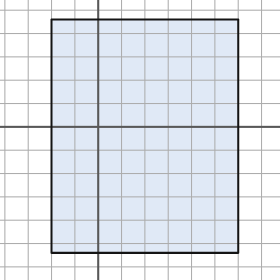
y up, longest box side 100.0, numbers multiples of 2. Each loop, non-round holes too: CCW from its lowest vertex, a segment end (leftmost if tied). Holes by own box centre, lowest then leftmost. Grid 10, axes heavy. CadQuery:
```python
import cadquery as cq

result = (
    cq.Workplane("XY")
    .moveTo(-20.0, -54.0)
    .lineTo(60.0, -54.0)
    .lineTo(60.0, 46.0)
    .lineTo(-20.0, 46.0)
    .close()
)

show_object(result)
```